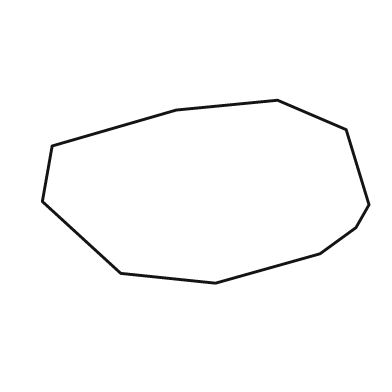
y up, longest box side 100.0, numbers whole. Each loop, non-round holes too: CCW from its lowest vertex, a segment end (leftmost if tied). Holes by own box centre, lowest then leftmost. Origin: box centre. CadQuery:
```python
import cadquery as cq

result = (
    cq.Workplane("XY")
    .moveTo(3.0, -28.0)
    .lineTo(35.0, -19.0)
    .lineTo(46.0, -11.0)
    .lineTo(50.0, -4.0)
    .lineTo(43.0, 19.0)
    .lineTo(22.0, 28.0)
    .lineTo(-9.0, 25.0)
    .lineTo(-47.0, 14.0)
    .lineTo(-50.0, -3.0)
    .lineTo(-26.0, -25.0)
    .close()
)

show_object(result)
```